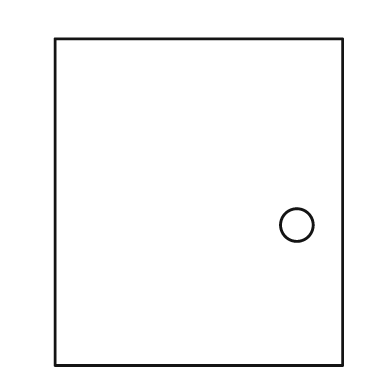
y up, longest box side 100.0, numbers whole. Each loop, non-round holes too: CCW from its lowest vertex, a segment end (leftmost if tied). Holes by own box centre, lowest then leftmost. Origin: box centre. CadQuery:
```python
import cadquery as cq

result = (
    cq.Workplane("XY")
    .moveTo(-44.0, -50.0)
    .lineTo(44.0, -50.0)
    .lineTo(44.0, 50.0)
    .lineTo(-44.0, 50.0)
    .close()
    .moveTo(30.0, -7.0)
    .circle(5.0)
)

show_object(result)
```